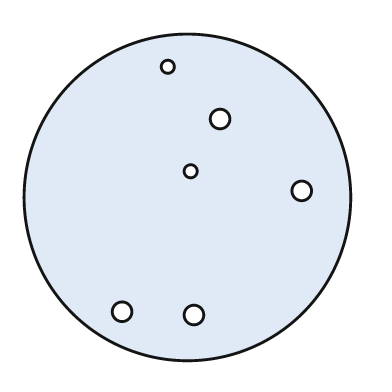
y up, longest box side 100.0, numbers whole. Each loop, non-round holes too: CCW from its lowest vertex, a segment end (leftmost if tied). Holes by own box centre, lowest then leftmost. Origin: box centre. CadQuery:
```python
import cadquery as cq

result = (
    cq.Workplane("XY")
    .moveTo(0.0, 0.0)
    .circle(50.0)
    .moveTo(2.0, -36.0)
    .circle(3.0)
    .moveTo(-20.0, -35.0)
    .circle(3.0)
    .moveTo(35.0, 2.0)
    .circle(3.0)
    .moveTo(1.0, 8.0)
    .circle(2.0)
    .moveTo(10.0, 24.0)
    .circle(3.0)
    .moveTo(-6.0, 40.0)
    .circle(2.0)
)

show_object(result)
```